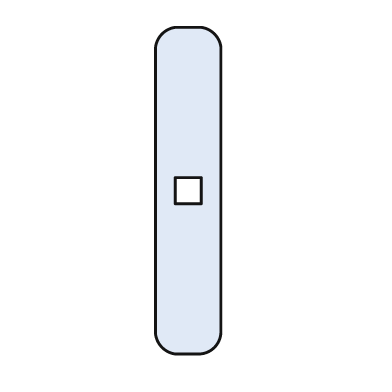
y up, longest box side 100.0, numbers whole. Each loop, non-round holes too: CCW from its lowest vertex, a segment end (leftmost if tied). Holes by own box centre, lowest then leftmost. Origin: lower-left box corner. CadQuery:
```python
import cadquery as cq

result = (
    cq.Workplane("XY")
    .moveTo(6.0, 0.0)
    .lineTo(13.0, 0.0)
    .threePointArc((18.0, 2.0), (20.0, 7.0))
    .lineTo(20.0, 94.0)
    .threePointArc((18.0, 98.0), (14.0, 100.0))
    .lineTo(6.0, 100.0)
    .threePointArc((2.0, 98.0), (0.0, 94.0))
    .lineTo(0.0, 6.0)
    .threePointArc((2.0, 2.0), (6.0, 0.0))
    .close()
    .moveTo(6.0, 46.0)
    .lineTo(14.0, 46.0)
    .lineTo(14.0, 54.0)
    .lineTo(6.0, 54.0)
    .close()
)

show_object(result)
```